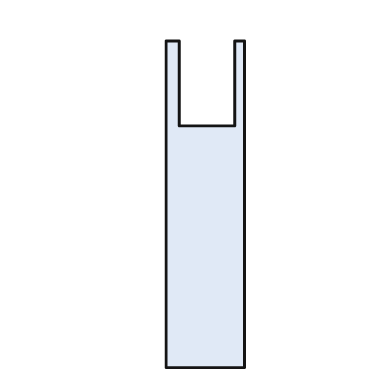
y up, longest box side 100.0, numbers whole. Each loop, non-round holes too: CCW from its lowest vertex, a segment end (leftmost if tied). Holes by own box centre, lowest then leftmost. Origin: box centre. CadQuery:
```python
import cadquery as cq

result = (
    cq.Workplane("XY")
    .moveTo(-12.0, -50.0)
    .lineTo(12.0, -50.0)
    .lineTo(12.0, 50.0)
    .lineTo(9.0, 50.0)
    .lineTo(9.0, 24.0)
    .lineTo(-8.0, 24.0)
    .lineTo(-8.0, 50.0)
    .lineTo(-12.0, 50.0)
    .close()
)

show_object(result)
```